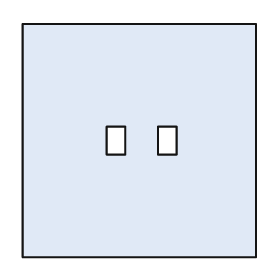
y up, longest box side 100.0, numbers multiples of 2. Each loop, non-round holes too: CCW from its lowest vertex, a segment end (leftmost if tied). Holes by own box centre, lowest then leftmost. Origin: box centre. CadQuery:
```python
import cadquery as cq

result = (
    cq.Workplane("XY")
    .moveTo(-50.0, -50.0)
    .lineTo(50.0, -50.0)
    .lineTo(50.0, 50.0)
    .lineTo(-50.0, 50.0)
    .close()
    .moveTo(-14.0, -6.0)
    .lineTo(-6.0, -6.0)
    .lineTo(-6.0, 6.0)
    .lineTo(-14.0, 6.0)
    .close()
    .moveTo(8.0, -6.0)
    .lineTo(16.0, -6.0)
    .lineTo(16.0, 6.0)
    .lineTo(8.0, 6.0)
    .close()
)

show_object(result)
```